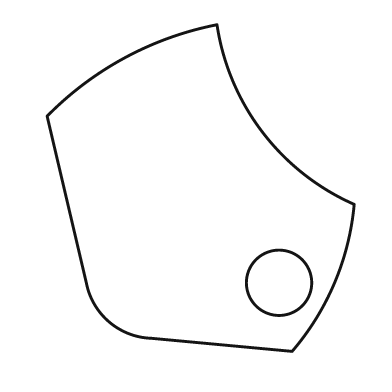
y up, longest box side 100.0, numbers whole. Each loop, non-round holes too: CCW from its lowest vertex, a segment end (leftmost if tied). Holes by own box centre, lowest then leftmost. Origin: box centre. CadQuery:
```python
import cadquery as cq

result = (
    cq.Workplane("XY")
    .moveTo(28.0, -50.0)
    .threePointArc((41.0, -29.0), (47.0, -5.0))
    .threePointArc((19.0, 17.0), (5.0, 50.0))
    .threePointArc((-23.0, 40.0), (-47.0, 22.0))
    .lineTo(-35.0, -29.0)
    .threePointArc((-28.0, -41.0), (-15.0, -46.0))
    .close()
    .moveTo(24.0, -29.0)
    .circle(10.0)
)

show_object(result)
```